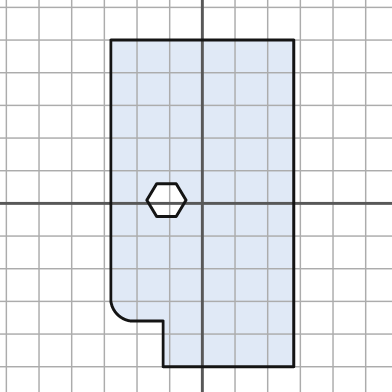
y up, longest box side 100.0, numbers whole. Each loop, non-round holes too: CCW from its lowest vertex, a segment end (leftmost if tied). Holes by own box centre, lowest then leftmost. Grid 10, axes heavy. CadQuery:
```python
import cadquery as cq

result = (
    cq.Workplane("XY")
    .moveTo(-12.0, -50.0)
    .lineTo(28.0, -50.0)
    .lineTo(28.0, 50.0)
    .lineTo(-28.0, 50.0)
    .lineTo(-28.0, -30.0)
    .threePointArc((-26.0, -34.0), (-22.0, -36.0))
    .lineTo(-12.0, -36.0)
    .close()
    .moveTo(-14.0, -4.0)
    .lineTo(-8.0, -4.0)
    .lineTo(-5.0, 1.0)
    .lineTo(-8.0, 6.0)
    .lineTo(-14.0, 6.0)
    .lineTo(-17.0, 1.0)
    .close()
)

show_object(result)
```